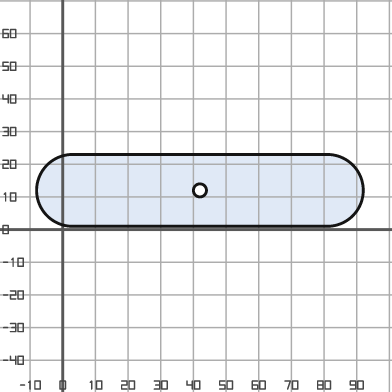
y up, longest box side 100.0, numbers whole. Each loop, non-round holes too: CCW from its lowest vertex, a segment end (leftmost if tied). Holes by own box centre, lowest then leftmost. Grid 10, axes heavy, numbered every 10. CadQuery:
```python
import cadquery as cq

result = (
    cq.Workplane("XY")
    .moveTo(3.0, 1.0)
    .lineTo(81.0, 1.0)
    .threePointArc((92.0, 12.0), (81.0, 23.0))
    .lineTo(3.0, 23.0)
    .threePointArc((-8.0, 12.0), (3.0, 1.0))
    .close()
    .moveTo(42.0, 12.0)
    .circle(2.0)
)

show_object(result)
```